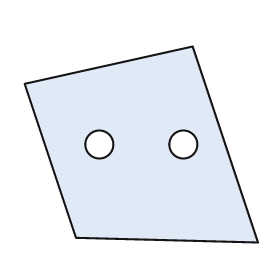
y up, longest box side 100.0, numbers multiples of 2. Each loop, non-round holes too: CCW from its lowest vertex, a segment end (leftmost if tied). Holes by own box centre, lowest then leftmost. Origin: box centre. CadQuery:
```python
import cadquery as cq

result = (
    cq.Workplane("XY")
    .moveTo(50.0, -42.0)
    .lineTo(22.0, 42.0)
    .lineTo(-50.0, 26.0)
    .lineTo(-28.0, -40.0)
    .close()
    .moveTo(-18.0, 0.0)
    .circle(6.0)
    .moveTo(18.0, 0.0)
    .circle(6.0)
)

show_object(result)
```